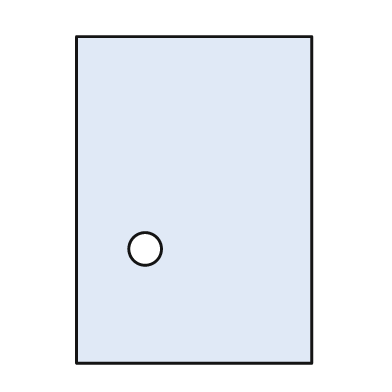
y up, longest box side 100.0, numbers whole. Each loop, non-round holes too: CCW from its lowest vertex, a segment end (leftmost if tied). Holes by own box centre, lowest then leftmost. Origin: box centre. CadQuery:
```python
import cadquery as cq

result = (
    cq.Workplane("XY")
    .moveTo(-36.0, -50.0)
    .lineTo(36.0, -50.0)
    .lineTo(36.0, 50.0)
    .lineTo(-36.0, 50.0)
    .close()
    .moveTo(-15.0, -15.0)
    .circle(5.0)
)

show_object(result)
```